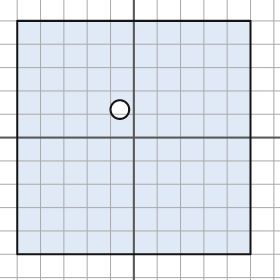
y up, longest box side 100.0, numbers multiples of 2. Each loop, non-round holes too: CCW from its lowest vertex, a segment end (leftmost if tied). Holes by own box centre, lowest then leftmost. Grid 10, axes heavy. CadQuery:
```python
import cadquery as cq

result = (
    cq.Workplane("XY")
    .moveTo(-50.0, -50.0)
    .lineTo(50.0, -50.0)
    .lineTo(50.0, 50.0)
    .lineTo(-50.0, 50.0)
    .close()
    .moveTo(-6.0, 12.0)
    .circle(4.0)
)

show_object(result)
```